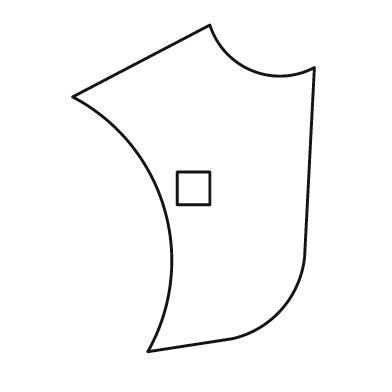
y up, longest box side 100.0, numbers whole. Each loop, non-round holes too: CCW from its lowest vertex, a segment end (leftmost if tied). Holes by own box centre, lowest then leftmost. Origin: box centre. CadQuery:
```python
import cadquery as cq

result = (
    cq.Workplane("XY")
    .moveTo(-14.0, -50.0)
    .lineTo(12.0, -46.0)
    .threePointArc((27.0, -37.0), (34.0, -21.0))
    .lineTo(37.0, 37.0)
    .threePointArc((18.0, 36.0), (5.0, 50.0))
    .lineTo(-37.0, 28.0)
    .threePointArc((-9.0, -6.0), (-14.0, -50.0))
    .close()
    .moveTo(-5.0, -5.0)
    .lineTo(5.0, -5.0)
    .lineTo(5.0, 5.0)
    .lineTo(-5.0, 5.0)
    .close()
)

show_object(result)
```